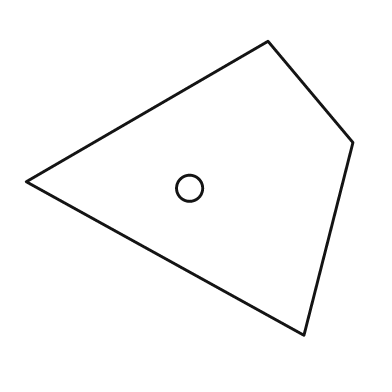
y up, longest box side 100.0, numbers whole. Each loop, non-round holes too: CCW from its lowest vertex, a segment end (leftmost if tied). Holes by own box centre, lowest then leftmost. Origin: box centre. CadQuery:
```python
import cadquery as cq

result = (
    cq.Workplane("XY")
    .moveTo(35.0, -45.0)
    .lineTo(50.0, 14.0)
    .lineTo(24.0, 45.0)
    .lineTo(-50.0, 2.0)
    .close()
    .moveTo(0.0, 0.0)
    .circle(4.0)
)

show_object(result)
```